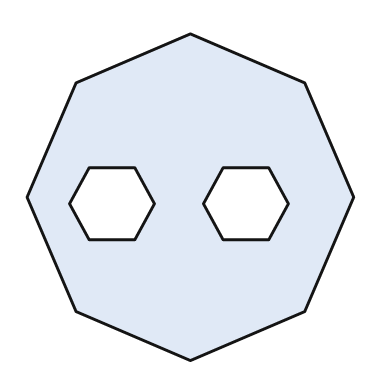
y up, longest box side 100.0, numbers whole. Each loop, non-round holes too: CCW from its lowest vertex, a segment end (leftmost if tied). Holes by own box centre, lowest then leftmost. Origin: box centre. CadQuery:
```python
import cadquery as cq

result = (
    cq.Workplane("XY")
    .moveTo(0.0, -50.0)
    .lineTo(35.0, -35.0)
    .lineTo(50.0, 0.0)
    .lineTo(35.0, 35.0)
    .lineTo(0.0, 50.0)
    .lineTo(-35.0, 35.0)
    .lineTo(-50.0, 0.0)
    .lineTo(-35.0, -35.0)
    .close()
    .moveTo(-31.0, -13.0)
    .lineTo(-17.0, -13.0)
    .lineTo(-11.0, -2.0)
    .lineTo(-17.0, 9.0)
    .lineTo(-31.0, 9.0)
    .lineTo(-37.0, -2.0)
    .close()
    .moveTo(10.0, -13.0)
    .lineTo(24.0, -13.0)
    .lineTo(30.0, -2.0)
    .lineTo(24.0, 9.0)
    .lineTo(10.0, 9.0)
    .lineTo(4.0, -2.0)
    .close()
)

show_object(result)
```